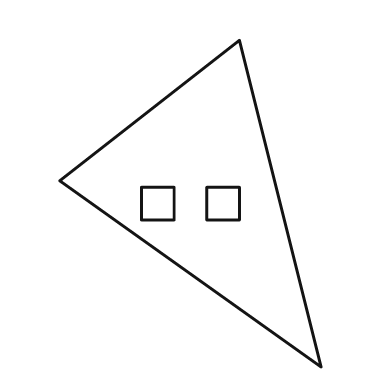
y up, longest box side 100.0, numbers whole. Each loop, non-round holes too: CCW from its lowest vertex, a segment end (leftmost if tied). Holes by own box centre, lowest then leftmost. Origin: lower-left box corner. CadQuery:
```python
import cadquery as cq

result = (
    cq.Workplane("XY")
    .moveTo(80.0, 0.0)
    .lineTo(55.0, 100.0)
    .lineTo(0.0, 57.0)
    .close()
    .moveTo(25.0, 45.0)
    .lineTo(35.0, 45.0)
    .lineTo(35.0, 55.0)
    .lineTo(25.0, 55.0)
    .close()
    .moveTo(45.0, 45.0)
    .lineTo(55.0, 45.0)
    .lineTo(55.0, 55.0)
    .lineTo(45.0, 55.0)
    .close()
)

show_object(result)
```